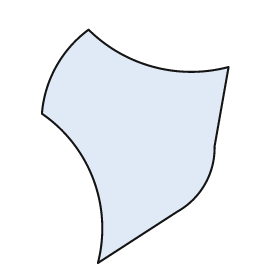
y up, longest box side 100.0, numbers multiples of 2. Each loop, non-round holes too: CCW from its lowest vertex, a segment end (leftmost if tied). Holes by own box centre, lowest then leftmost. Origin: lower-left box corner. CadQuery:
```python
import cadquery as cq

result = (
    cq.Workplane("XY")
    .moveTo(24.0, 0.0)
    .lineTo(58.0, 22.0)
    .threePointArc((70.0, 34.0), (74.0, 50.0))
    .lineTo(80.0, 84.0)
    .threePointArc((48.0, 84.0), (20.0, 100.0))
    .threePointArc((6.0, 84.0), (0.0, 64.0))
    .threePointArc((22.0, 36.0), (24.0, 0.0))
    .close()
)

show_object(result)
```